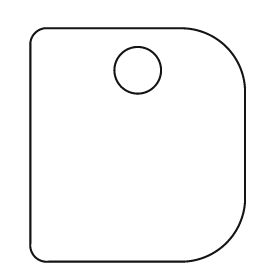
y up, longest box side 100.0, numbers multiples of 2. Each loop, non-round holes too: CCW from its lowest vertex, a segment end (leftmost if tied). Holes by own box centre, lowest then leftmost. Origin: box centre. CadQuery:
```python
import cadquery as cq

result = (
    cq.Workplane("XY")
    .moveTo(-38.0, -50.0)
    .lineTo(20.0, -50.0)
    .threePointArc((38.0, -42.0), (46.0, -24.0))
    .lineTo(46.0, 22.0)
    .threePointArc((38.0, 42.0), (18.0, 50.0))
    .lineTo(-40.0, 50.0)
    .threePointArc((-44.0, 48.0), (-46.0, 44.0))
    .lineTo(-46.0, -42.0)
    .threePointArc((-44.0, -48.0), (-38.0, -50.0))
    .close()
    .moveTo(0.0, 32.0)
    .circle(10.0)
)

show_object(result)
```